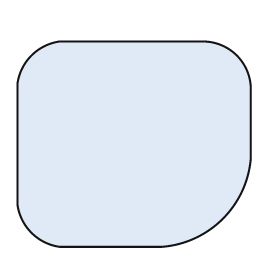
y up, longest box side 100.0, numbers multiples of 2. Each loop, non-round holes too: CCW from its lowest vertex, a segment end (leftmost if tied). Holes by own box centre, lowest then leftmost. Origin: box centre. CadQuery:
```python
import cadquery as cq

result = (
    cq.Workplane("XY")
    .moveTo(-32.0, -44.0)
    .lineTo(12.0, -44.0)
    .threePointArc((38.0, -32.0), (50.0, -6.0))
    .lineTo(50.0, 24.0)
    .threePointArc((44.0, 38.0), (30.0, 44.0))
    .lineTo(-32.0, 44.0)
    .threePointArc((-44.0, 38.0), (-50.0, 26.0))
    .lineTo(-50.0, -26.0)
    .threePointArc((-44.0, -38.0), (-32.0, -44.0))
    .close()
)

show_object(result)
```